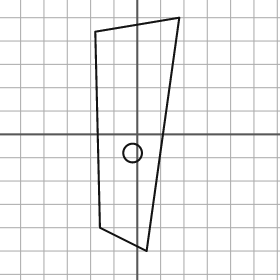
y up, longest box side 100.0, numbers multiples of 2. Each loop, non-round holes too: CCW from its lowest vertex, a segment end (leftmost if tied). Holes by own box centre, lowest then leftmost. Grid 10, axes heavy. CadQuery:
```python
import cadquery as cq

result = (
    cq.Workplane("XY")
    .moveTo(4.0, -50.0)
    .lineTo(18.0, 50.0)
    .lineTo(-18.0, 44.0)
    .lineTo(-16.0, -40.0)
    .close()
    .moveTo(-2.0, -8.0)
    .circle(4.0)
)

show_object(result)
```